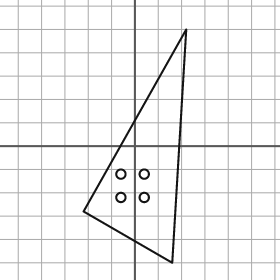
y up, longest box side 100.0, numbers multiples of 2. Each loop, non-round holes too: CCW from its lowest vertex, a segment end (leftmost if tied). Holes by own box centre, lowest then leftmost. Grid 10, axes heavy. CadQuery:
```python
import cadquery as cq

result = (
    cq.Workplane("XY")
    .moveTo(16.0, -50.0)
    .lineTo(22.0, 50.0)
    .lineTo(-22.0, -28.0)
    .close()
    .moveTo(-6.0, -22.0)
    .circle(2.0)
    .moveTo(4.0, -22.0)
    .circle(2.0)
    .moveTo(-6.0, -12.0)
    .circle(2.0)
    .moveTo(4.0, -12.0)
    .circle(2.0)
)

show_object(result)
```